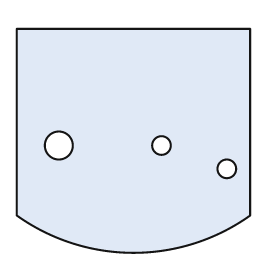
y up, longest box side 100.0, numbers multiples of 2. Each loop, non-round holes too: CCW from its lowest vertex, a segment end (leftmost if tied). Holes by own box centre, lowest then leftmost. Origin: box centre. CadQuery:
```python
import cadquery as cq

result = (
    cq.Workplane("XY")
    .moveTo(-50.0, -32.0)
    .threePointArc((0.0, -48.0), (50.0, -32.0))
    .lineTo(50.0, 48.0)
    .lineTo(-50.0, 48.0)
    .close()
    .moveTo(40.0, -12.0)
    .circle(4.0)
    .moveTo(-32.0, -2.0)
    .circle(6.0)
    .moveTo(12.0, -2.0)
    .circle(4.0)
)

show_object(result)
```